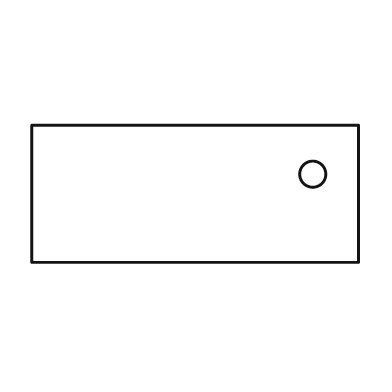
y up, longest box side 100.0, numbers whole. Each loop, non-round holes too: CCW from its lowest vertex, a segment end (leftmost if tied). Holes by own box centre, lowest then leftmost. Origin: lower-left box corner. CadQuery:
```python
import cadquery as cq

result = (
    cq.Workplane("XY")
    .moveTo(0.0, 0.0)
    .lineTo(100.0, 0.0)
    .lineTo(100.0, 42.0)
    .lineTo(0.0, 42.0)
    .close()
    .moveTo(86.0, 27.0)
    .circle(4.0)
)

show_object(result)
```